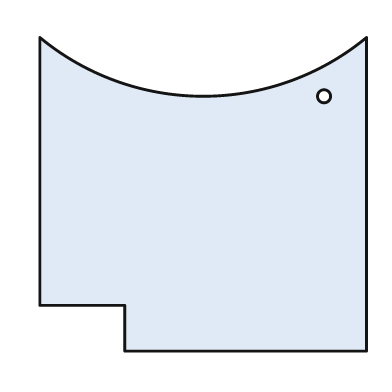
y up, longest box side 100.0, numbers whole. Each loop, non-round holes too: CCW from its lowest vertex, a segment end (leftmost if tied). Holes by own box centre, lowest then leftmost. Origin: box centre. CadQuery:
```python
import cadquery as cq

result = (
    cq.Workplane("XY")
    .moveTo(-24.0, -48.0)
    .lineTo(50.0, -48.0)
    .lineTo(50.0, 48.0)
    .threePointArc((0.0, 30.0), (-50.0, 48.0))
    .lineTo(-50.0, -34.0)
    .lineTo(-24.0, -34.0)
    .close()
    .moveTo(37.0, 30.0)
    .circle(2.0)
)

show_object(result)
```